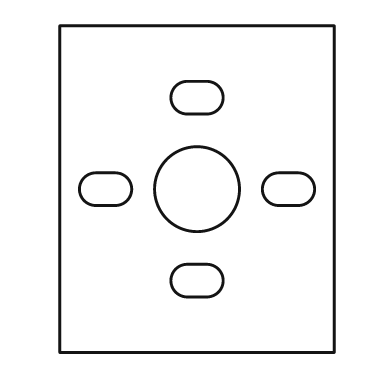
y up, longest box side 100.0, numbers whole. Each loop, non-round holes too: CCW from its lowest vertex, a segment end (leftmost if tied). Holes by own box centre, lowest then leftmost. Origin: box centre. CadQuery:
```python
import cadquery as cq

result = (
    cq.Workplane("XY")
    .moveTo(-42.0, -50.0)
    .lineTo(42.0, -50.0)
    .lineTo(42.0, 50.0)
    .lineTo(-42.0, 50.0)
    .close()
    .moveTo(-3.0, -33.0)
    .lineTo(3.0, -33.0)
    .threePointArc((8.0, -28.0), (3.0, -23.0))
    .lineTo(-3.0, -23.0)
    .threePointArc((-8.0, -28.0), (-3.0, -33.0))
    .close()
    .moveTo(-31.0, -5.0)
    .lineTo(-25.0, -5.0)
    .threePointArc((-20.0, 0.0), (-25.0, 5.0))
    .lineTo(-31.0, 5.0)
    .threePointArc((-36.0, 0.0), (-31.0, -5.0))
    .close()
    .moveTo(0.0, 0.0)
    .circle(13.0)
    .moveTo(25.0, -5.0)
    .lineTo(31.0, -5.0)
    .threePointArc((36.0, 0.0), (31.0, 5.0))
    .lineTo(25.0, 5.0)
    .threePointArc((20.0, 0.0), (25.0, -5.0))
    .close()
    .moveTo(-3.0, 23.0)
    .lineTo(3.0, 23.0)
    .threePointArc((8.0, 28.0), (3.0, 33.0))
    .lineTo(-3.0, 33.0)
    .threePointArc((-8.0, 28.0), (-3.0, 23.0))
    .close()
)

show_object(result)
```